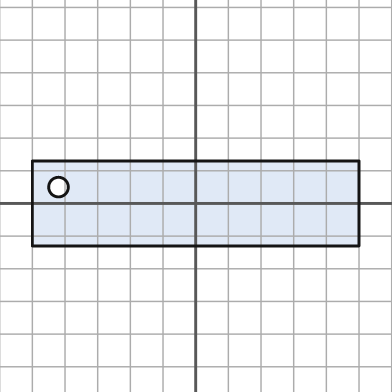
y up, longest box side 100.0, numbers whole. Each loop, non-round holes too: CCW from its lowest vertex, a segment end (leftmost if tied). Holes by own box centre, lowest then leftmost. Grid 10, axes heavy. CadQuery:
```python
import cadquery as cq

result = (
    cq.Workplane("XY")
    .moveTo(-50.0, -13.0)
    .lineTo(50.0, -13.0)
    .lineTo(50.0, 13.0)
    .lineTo(-50.0, 13.0)
    .close()
    .moveTo(-42.0, 5.0)
    .circle(3.0)
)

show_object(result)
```